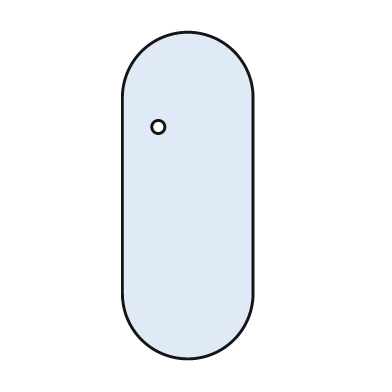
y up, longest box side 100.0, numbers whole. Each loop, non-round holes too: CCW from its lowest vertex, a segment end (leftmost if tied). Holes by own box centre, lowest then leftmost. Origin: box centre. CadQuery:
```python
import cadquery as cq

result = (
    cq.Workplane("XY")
    .moveTo(-20.0, -30.0)
    .threePointArc((0.0, -50.0), (20.0, -30.0))
    .lineTo(20.0, 30.0)
    .threePointArc((0.0, 50.0), (-20.0, 30.0))
    .close()
    .moveTo(-9.0, 21.0)
    .circle(2.0)
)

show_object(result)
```